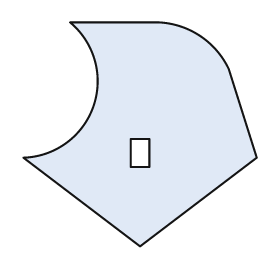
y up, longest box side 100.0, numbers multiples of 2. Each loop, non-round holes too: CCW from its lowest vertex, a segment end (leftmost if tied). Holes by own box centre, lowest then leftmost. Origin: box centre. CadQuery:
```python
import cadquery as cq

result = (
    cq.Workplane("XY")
    .moveTo(0.0, -48.0)
    .lineTo(50.0, -10.0)
    .lineTo(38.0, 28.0)
    .threePointArc((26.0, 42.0), (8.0, 48.0))
    .lineTo(-30.0, 48.0)
    .threePointArc((-20.0, 12.0), (-50.0, -10.0))
    .close()
    .moveTo(-4.0, -14.0)
    .lineTo(4.0, -14.0)
    .lineTo(4.0, -2.0)
    .lineTo(-4.0, -2.0)
    .close()
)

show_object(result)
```